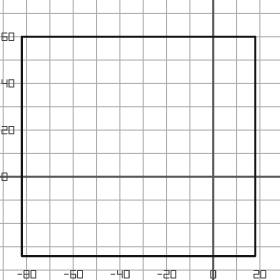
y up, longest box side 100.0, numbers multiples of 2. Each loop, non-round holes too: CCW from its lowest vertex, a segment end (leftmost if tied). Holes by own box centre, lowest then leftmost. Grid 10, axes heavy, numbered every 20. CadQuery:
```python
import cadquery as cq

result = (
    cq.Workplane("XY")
    .moveTo(-82.0, -34.0)
    .lineTo(18.0, -34.0)
    .lineTo(18.0, 60.0)
    .lineTo(-82.0, 60.0)
    .close()
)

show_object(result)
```